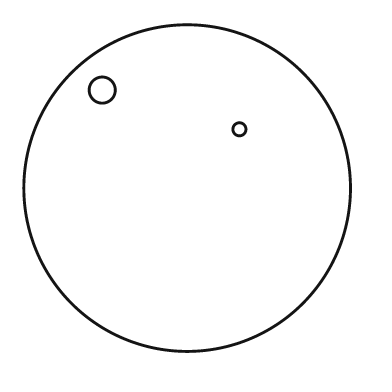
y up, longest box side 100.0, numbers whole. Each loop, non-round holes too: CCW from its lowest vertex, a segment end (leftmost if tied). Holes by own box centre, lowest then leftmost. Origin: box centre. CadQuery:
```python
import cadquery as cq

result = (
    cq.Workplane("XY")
    .moveTo(0.0, 0.0)
    .circle(50.0)
    .moveTo(16.0, 18.0)
    .circle(2.0)
    .moveTo(-26.0, 30.0)
    .circle(4.0)
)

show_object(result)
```